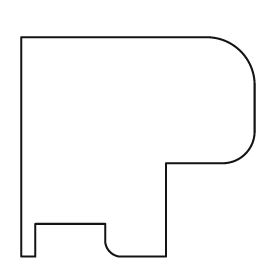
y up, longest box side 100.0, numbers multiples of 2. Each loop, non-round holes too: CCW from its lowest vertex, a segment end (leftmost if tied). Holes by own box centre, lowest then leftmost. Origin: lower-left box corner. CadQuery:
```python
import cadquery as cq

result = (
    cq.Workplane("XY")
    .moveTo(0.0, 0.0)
    .lineTo(6.0, 0.0)
    .lineTo(6.0, 14.0)
    .lineTo(36.0, 14.0)
    .lineTo(36.0, 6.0)
    .threePointArc((38.0, 2.0), (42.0, 0.0))
    .lineTo(62.0, 0.0)
    .lineTo(62.0, 40.0)
    .lineTo(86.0, 40.0)
    .threePointArc((96.0, 44.0), (100.0, 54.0))
    .lineTo(100.0, 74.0)
    .threePointArc((94.0, 88.0), (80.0, 94.0))
    .lineTo(0.0, 94.0)
    .close()
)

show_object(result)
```